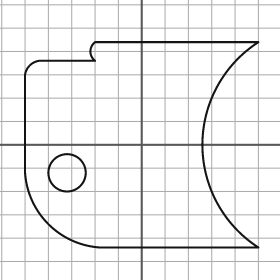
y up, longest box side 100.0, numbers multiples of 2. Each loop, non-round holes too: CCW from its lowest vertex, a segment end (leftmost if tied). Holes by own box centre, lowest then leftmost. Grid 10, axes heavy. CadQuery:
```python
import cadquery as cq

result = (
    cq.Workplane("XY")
    .moveTo(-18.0, -44.0)
    .lineTo(50.0, -44.0)
    .threePointArc((26.0, 0.0), (50.0, 44.0))
    .lineTo(-20.0, 44.0)
    .threePointArc((-22.0, 40.0), (-20.0, 36.0))
    .lineTo(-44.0, 36.0)
    .threePointArc((-48.0, 34.0), (-50.0, 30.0))
    .lineTo(-50.0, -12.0)
    .threePointArc((-40.0, -34.0), (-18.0, -44.0))
    .close()
    .moveTo(-32.0, -12.0)
    .circle(8.0)
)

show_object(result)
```